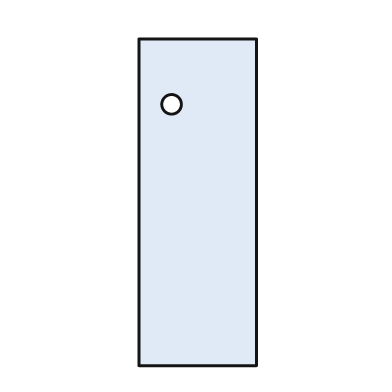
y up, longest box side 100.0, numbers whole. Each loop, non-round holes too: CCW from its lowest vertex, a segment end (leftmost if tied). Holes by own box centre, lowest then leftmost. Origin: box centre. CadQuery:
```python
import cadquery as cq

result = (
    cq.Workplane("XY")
    .moveTo(-18.0, -50.0)
    .lineTo(18.0, -50.0)
    .lineTo(18.0, 50.0)
    .lineTo(-18.0, 50.0)
    .close()
    .moveTo(-8.0, 30.0)
    .circle(3.0)
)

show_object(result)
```